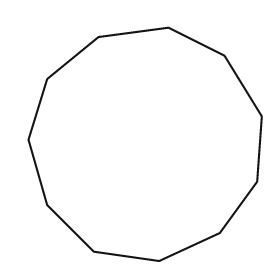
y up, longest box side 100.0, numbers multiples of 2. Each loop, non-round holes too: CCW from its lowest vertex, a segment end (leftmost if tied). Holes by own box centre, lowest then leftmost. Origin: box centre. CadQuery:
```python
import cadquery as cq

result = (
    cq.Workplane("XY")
    .moveTo(6.0, -50.0)
    .lineTo(32.0, -38.0)
    .lineTo(48.0, -16.0)
    .lineTo(50.0, 12.0)
    .lineTo(34.0, 38.0)
    .lineTo(10.0, 50.0)
    .lineTo(-20.0, 46.0)
    .lineTo(-42.0, 28.0)
    .lineTo(-50.0, 2.0)
    .lineTo(-42.0, -26.0)
    .lineTo(-22.0, -46.0)
    .close()
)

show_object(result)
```